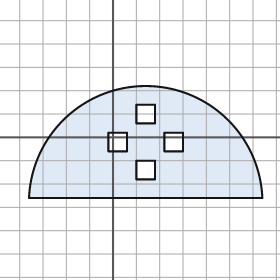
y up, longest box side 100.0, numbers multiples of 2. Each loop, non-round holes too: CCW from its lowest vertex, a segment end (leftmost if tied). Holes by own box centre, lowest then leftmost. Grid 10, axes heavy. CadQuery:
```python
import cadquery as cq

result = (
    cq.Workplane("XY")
    .moveTo(-36.0, -26.0)
    .lineTo(64.0, -26.0)
    .threePointArc((14.0, 22.0), (-36.0, -26.0))
    .close()
    .moveTo(10.0, -18.0)
    .lineTo(18.0, -18.0)
    .lineTo(18.0, -10.0)
    .lineTo(10.0, -10.0)
    .close()
    .moveTo(-2.0, -6.0)
    .lineTo(6.0, -6.0)
    .lineTo(6.0, 2.0)
    .lineTo(-2.0, 2.0)
    .close()
    .moveTo(22.0, -6.0)
    .lineTo(30.0, -6.0)
    .lineTo(30.0, 2.0)
    .lineTo(22.0, 2.0)
    .close()
    .moveTo(10.0, 6.0)
    .lineTo(18.0, 6.0)
    .lineTo(18.0, 14.0)
    .lineTo(10.0, 14.0)
    .close()
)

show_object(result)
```